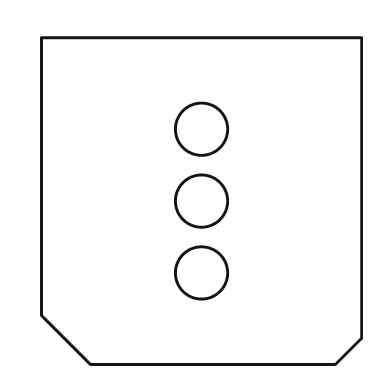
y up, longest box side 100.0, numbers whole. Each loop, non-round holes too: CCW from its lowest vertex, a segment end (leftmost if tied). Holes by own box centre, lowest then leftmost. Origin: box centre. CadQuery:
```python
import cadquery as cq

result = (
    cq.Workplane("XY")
    .moveTo(-34.0, -50.0)
    .lineTo(41.0, -50.0)
    .lineTo(49.0, -42.0)
    .lineTo(49.0, 50.0)
    .lineTo(-49.0, 50.0)
    .lineTo(-49.0, -35.0)
    .close()
    .moveTo(0.0, -22.0)
    .circle(8.0)
    .moveTo(0.0, 0.0)
    .circle(8.0)
    .moveTo(0.0, 22.0)
    .circle(8.0)
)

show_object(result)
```